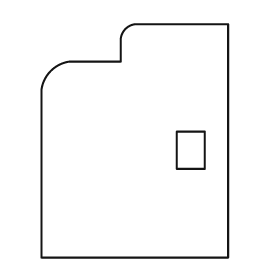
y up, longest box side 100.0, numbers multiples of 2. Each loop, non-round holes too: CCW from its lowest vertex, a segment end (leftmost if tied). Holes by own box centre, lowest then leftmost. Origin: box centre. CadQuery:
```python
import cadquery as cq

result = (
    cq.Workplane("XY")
    .moveTo(-40.0, -50.0)
    .lineTo(40.0, -50.0)
    .lineTo(40.0, 50.0)
    .lineTo(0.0, 50.0)
    .threePointArc((-4.0, 48.0), (-6.0, 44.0))
    .lineTo(-6.0, 34.0)
    .lineTo(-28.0, 34.0)
    .threePointArc((-36.0, 30.0), (-40.0, 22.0))
    .close()
    .moveTo(18.0, -12.0)
    .lineTo(30.0, -12.0)
    .lineTo(30.0, 4.0)
    .lineTo(18.0, 4.0)
    .close()
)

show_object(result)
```